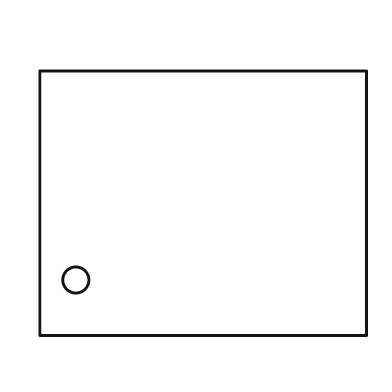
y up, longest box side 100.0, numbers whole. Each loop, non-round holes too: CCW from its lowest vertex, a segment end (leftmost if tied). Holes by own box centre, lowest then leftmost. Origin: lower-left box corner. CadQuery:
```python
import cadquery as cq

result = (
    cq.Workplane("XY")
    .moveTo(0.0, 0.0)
    .lineTo(100.0, 0.0)
    .lineTo(100.0, 81.0)
    .lineTo(0.0, 81.0)
    .close()
    .moveTo(11.0, 17.0)
    .circle(4.0)
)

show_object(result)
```